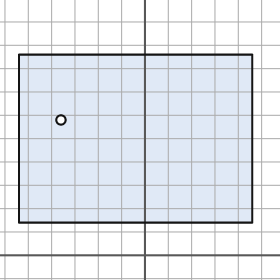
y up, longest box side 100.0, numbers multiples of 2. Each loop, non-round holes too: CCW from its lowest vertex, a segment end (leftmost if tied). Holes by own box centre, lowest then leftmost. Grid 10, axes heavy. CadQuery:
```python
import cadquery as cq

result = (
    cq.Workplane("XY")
    .moveTo(-54.0, 14.0)
    .lineTo(46.0, 14.0)
    .lineTo(46.0, 86.0)
    .lineTo(-54.0, 86.0)
    .close()
    .moveTo(-36.0, 58.0)
    .circle(2.0)
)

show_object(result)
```